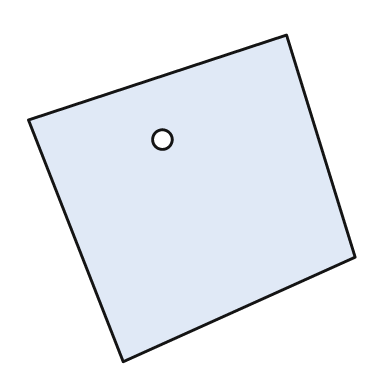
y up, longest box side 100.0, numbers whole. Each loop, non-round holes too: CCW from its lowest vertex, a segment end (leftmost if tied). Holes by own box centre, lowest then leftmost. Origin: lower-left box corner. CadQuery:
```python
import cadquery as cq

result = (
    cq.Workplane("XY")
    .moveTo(29.0, 0.0)
    .lineTo(100.0, 32.0)
    .lineTo(79.0, 100.0)
    .lineTo(0.0, 74.0)
    .close()
    .moveTo(41.0, 68.0)
    .circle(3.0)
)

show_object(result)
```